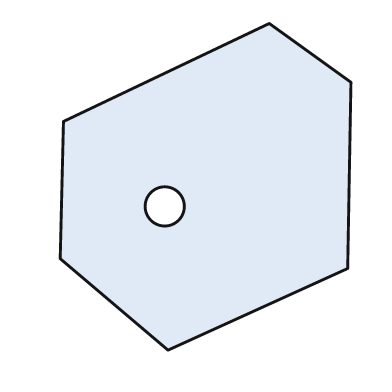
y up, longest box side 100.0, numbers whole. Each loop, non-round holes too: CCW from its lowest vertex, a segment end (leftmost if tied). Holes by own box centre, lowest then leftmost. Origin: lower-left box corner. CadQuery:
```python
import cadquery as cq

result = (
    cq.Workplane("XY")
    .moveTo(33.0, 0.0)
    .lineTo(88.0, 25.0)
    .lineTo(89.0, 82.0)
    .lineTo(64.0, 100.0)
    .lineTo(1.0, 70.0)
    .lineTo(0.0, 28.0)
    .close()
    .moveTo(32.0, 44.0)
    .circle(6.0)
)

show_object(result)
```